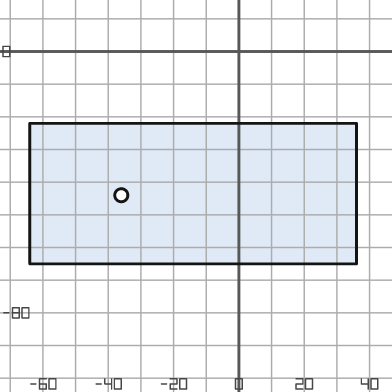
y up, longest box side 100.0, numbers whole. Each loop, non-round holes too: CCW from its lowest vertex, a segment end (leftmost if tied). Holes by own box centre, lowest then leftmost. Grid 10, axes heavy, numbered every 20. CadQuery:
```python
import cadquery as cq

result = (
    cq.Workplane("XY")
    .moveTo(-64.0, -65.0)
    .lineTo(36.0, -65.0)
    .lineTo(36.0, -22.0)
    .lineTo(-64.0, -22.0)
    .close()
    .moveTo(-36.0, -44.0)
    .circle(2.0)
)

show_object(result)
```